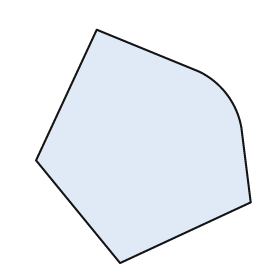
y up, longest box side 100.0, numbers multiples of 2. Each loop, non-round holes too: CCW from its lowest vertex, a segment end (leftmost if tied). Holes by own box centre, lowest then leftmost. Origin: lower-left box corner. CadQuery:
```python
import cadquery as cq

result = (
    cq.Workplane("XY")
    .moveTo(36.0, 0.0)
    .lineTo(92.0, 26.0)
    .lineTo(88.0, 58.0)
    .threePointArc((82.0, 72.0), (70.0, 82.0))
    .lineTo(26.0, 100.0)
    .lineTo(0.0, 44.0)
    .close()
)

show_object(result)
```